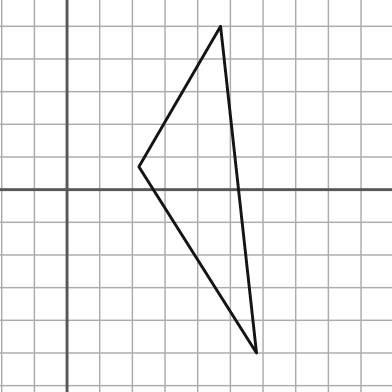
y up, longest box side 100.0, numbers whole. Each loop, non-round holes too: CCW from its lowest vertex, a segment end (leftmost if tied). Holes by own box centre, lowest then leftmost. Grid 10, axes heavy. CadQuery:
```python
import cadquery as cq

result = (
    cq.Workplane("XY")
    .moveTo(58.0, -50.0)
    .lineTo(47.0, 50.0)
    .lineTo(22.0, 7.0)
    .close()
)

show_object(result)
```